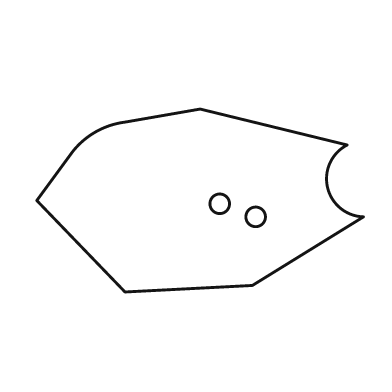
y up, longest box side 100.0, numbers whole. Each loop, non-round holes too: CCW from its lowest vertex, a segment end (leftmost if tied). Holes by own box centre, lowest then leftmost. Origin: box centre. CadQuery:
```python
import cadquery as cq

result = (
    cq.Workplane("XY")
    .moveTo(-23.0, -28.0)
    .lineTo(16.0, -26.0)
    .lineTo(50.0, -5.0)
    .threePointArc((39.0, 4.0), (45.0, 17.0))
    .lineTo(0.0, 28.0)
    .lineTo(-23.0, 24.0)
    .threePointArc((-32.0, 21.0), (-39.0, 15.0))
    .lineTo(-50.0, 0.0)
    .close()
    .moveTo(17.0, -5.0)
    .circle(3.0)
    .moveTo(6.0, -1.0)
    .circle(3.0)
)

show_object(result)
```